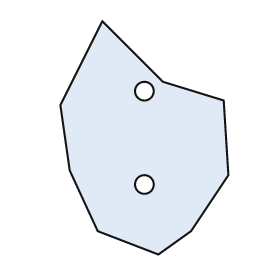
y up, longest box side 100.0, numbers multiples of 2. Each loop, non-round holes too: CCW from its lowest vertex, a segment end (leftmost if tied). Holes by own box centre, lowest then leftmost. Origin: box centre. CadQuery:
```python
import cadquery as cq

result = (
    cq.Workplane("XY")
    .moveTo(6.0, -50.0)
    .lineTo(20.0, -40.0)
    .lineTo(36.0, -16.0)
    .lineTo(34.0, 16.0)
    .lineTo(8.0, 24.0)
    .lineTo(-18.0, 50.0)
    .lineTo(-36.0, 14.0)
    .lineTo(-32.0, -14.0)
    .lineTo(-20.0, -40.0)
    .close()
    .moveTo(0.0, -20.0)
    .circle(4.0)
    .moveTo(0.0, 20.0)
    .circle(4.0)
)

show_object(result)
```